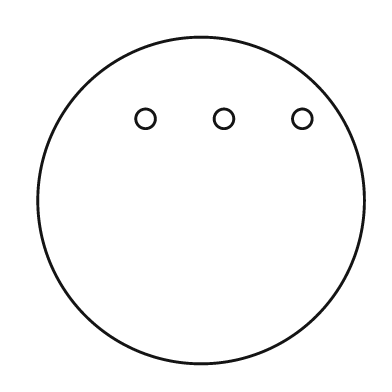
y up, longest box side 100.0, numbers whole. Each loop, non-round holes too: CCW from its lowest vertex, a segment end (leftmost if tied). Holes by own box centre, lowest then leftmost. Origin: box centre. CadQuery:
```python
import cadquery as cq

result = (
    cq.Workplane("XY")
    .moveTo(0.0, 0.0)
    .circle(50.0)
    .moveTo(-17.0, 25.0)
    .circle(3.0)
    .moveTo(7.0, 25.0)
    .circle(3.0)
    .moveTo(31.0, 25.0)
    .circle(3.0)
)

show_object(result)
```